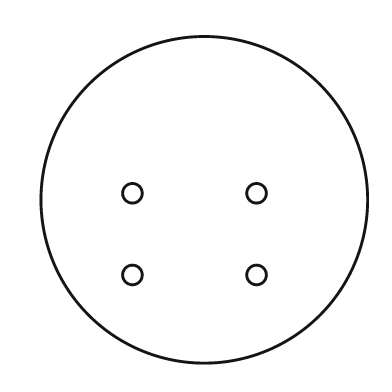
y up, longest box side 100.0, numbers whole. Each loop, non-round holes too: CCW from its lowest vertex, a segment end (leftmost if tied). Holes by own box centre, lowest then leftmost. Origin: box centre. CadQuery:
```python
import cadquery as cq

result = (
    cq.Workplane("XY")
    .moveTo(0.0, 0.0)
    .circle(50.0)
    .moveTo(-22.0, -23.0)
    .circle(3.0)
    .moveTo(16.0, -23.0)
    .circle(3.0)
    .moveTo(-22.0, 2.0)
    .circle(3.0)
    .moveTo(16.0, 2.0)
    .circle(3.0)
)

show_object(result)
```